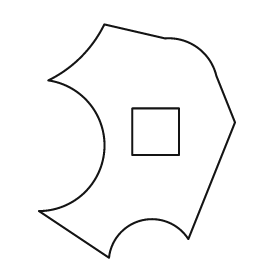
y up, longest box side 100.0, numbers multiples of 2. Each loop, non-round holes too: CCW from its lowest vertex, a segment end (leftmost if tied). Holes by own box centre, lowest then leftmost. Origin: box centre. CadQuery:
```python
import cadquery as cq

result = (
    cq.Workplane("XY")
    .moveTo(-12.0, -50.0)
    .threePointArc((2.0, -34.0), (22.0, -42.0))
    .lineTo(42.0, 8.0)
    .lineTo(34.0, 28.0)
    .threePointArc((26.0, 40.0), (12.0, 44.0))
    .lineTo(-14.0, 50.0)
    .threePointArc((-24.0, 36.0), (-38.0, 26.0))
    .threePointArc((-14.0, -4.0), (-42.0, -30.0))
    .close()
    .moveTo(-2.0, -6.0)
    .lineTo(18.0, -6.0)
    .lineTo(18.0, 14.0)
    .lineTo(-2.0, 14.0)
    .close()
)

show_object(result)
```